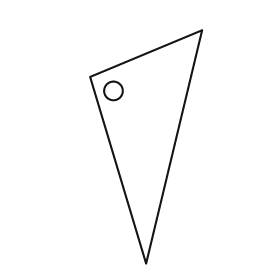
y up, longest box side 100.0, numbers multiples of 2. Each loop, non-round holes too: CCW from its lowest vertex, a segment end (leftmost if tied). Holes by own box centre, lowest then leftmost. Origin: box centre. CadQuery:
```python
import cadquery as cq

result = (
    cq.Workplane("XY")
    .moveTo(0.0, -50.0)
    .lineTo(24.0, 50.0)
    .lineTo(-24.0, 30.0)
    .close()
    .moveTo(-14.0, 24.0)
    .circle(4.0)
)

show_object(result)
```